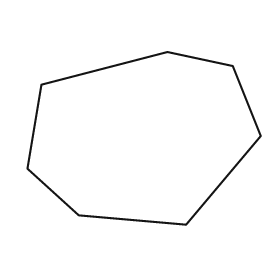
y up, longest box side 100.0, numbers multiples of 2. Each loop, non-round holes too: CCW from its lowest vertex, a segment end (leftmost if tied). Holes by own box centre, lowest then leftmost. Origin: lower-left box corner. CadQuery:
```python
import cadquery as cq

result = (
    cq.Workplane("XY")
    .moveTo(68.0, 0.0)
    .lineTo(100.0, 38.0)
    .lineTo(88.0, 68.0)
    .lineTo(60.0, 74.0)
    .lineTo(6.0, 60.0)
    .lineTo(0.0, 24.0)
    .lineTo(22.0, 4.0)
    .close()
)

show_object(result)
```